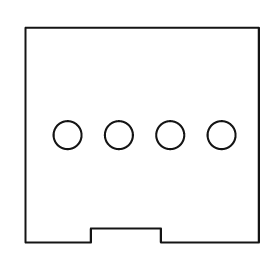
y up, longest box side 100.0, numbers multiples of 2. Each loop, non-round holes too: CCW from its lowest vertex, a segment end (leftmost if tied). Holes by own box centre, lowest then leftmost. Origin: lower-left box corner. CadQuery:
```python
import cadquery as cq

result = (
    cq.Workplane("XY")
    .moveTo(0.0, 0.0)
    .lineTo(28.0, 0.0)
    .lineTo(28.0, 6.0)
    .lineTo(58.0, 6.0)
    .lineTo(58.0, 0.0)
    .lineTo(100.0, 0.0)
    .lineTo(100.0, 92.0)
    .lineTo(0.0, 92.0)
    .close()
    .moveTo(18.0, 46.0)
    .circle(6.0)
    .moveTo(40.0, 46.0)
    .circle(6.0)
    .moveTo(62.0, 46.0)
    .circle(6.0)
    .moveTo(84.0, 46.0)
    .circle(6.0)
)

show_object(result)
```